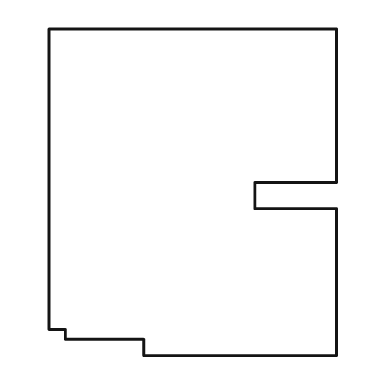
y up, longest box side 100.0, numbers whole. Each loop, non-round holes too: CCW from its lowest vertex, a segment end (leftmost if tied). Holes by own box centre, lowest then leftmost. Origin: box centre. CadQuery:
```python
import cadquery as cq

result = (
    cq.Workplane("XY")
    .moveTo(-15.0, -50.0)
    .lineTo(44.0, -50.0)
    .lineTo(44.0, -5.0)
    .lineTo(19.0, -5.0)
    .lineTo(19.0, 3.0)
    .lineTo(44.0, 3.0)
    .lineTo(44.0, 50.0)
    .lineTo(-44.0, 50.0)
    .lineTo(-44.0, -42.0)
    .lineTo(-39.0, -42.0)
    .lineTo(-39.0, -45.0)
    .lineTo(-15.0, -45.0)
    .close()
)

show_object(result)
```